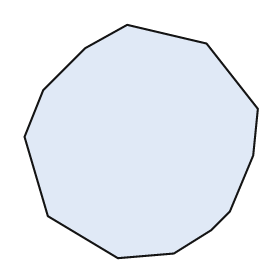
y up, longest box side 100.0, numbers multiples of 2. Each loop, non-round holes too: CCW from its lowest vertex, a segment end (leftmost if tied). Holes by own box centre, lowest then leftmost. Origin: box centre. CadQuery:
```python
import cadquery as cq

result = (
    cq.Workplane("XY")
    .moveTo(-10.0, -50.0)
    .lineTo(14.0, -48.0)
    .lineTo(30.0, -38.0)
    .lineTo(38.0, -30.0)
    .lineTo(48.0, -6.0)
    .lineTo(50.0, 14.0)
    .lineTo(28.0, 42.0)
    .lineTo(-6.0, 50.0)
    .lineTo(-24.0, 40.0)
    .lineTo(-42.0, 22.0)
    .lineTo(-50.0, 2.0)
    .lineTo(-40.0, -32.0)
    .close()
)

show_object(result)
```